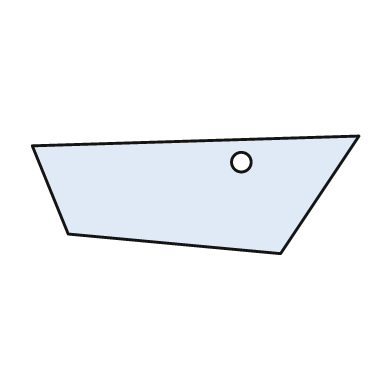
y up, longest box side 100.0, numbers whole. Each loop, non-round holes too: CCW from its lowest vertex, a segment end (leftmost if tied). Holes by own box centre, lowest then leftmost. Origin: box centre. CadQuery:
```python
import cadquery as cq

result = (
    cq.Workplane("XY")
    .moveTo(26.0, -18.0)
    .lineTo(50.0, 18.0)
    .lineTo(-50.0, 15.0)
    .lineTo(-39.0, -12.0)
    .close()
    .moveTo(14.0, 10.0)
    .circle(3.0)
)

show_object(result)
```